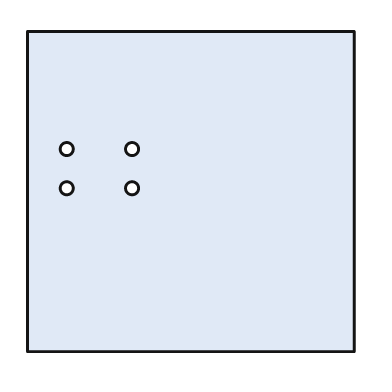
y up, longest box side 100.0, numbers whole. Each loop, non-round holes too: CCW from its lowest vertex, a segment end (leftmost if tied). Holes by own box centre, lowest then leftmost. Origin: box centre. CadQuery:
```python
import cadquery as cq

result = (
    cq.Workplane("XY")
    .moveTo(-50.0, -49.0)
    .lineTo(50.0, -49.0)
    .lineTo(50.0, 49.0)
    .lineTo(-50.0, 49.0)
    .close()
    .moveTo(-38.0, 1.0)
    .circle(2.0)
    .moveTo(-18.0, 1.0)
    .circle(2.0)
    .moveTo(-38.0, 13.0)
    .circle(2.0)
    .moveTo(-18.0, 13.0)
    .circle(2.0)
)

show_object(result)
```